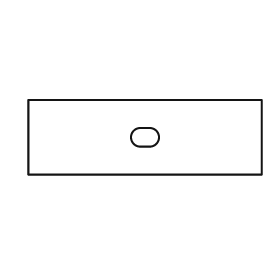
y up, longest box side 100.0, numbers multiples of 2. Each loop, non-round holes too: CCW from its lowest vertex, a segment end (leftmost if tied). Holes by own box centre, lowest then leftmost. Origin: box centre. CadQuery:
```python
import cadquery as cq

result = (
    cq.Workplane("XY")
    .moveTo(-50.0, -16.0)
    .lineTo(50.0, -16.0)
    .lineTo(50.0, 16.0)
    .lineTo(-50.0, 16.0)
    .close()
    .moveTo(-2.0, -4.0)
    .lineTo(2.0, -4.0)
    .threePointArc((6.0, 0.0), (2.0, 4.0))
    .lineTo(-2.0, 4.0)
    .threePointArc((-6.0, 0.0), (-2.0, -4.0))
    .close()
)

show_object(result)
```